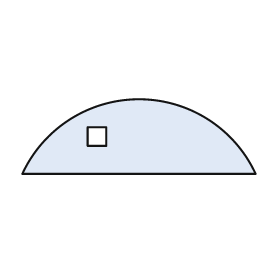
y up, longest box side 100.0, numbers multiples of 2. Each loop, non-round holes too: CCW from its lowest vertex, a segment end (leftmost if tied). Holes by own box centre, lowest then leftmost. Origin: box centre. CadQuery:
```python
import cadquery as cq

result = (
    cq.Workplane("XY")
    .moveTo(-50.0, -16.0)
    .lineTo(50.0, -16.0)
    .threePointArc((0.0, 16.0), (-50.0, -16.0))
    .close()
    .moveTo(-22.0, -4.0)
    .lineTo(-14.0, -4.0)
    .lineTo(-14.0, 4.0)
    .lineTo(-22.0, 4.0)
    .close()
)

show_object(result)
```